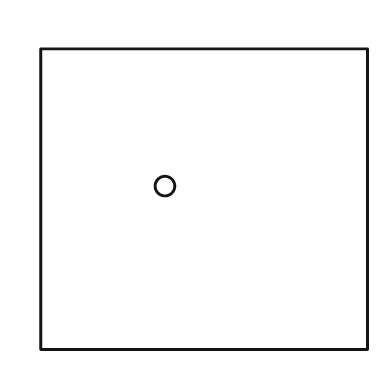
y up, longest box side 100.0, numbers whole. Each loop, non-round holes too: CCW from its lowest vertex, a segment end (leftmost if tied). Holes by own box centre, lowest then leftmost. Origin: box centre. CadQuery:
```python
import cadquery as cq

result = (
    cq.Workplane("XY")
    .moveTo(-50.0, -46.0)
    .lineTo(50.0, -46.0)
    .lineTo(50.0, 46.0)
    .lineTo(-50.0, 46.0)
    .close()
    .moveTo(-12.0, 4.0)
    .circle(3.0)
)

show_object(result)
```